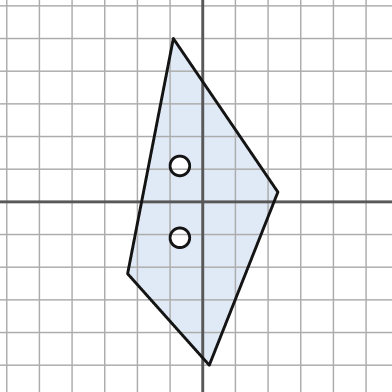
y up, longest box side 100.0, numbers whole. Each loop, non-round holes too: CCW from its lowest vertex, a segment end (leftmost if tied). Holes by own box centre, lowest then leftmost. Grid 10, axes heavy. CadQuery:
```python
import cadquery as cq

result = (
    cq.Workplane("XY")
    .moveTo(2.0, -50.0)
    .lineTo(23.0, 3.0)
    .lineTo(-9.0, 50.0)
    .lineTo(-23.0, -22.0)
    .close()
    .moveTo(-7.0, -11.0)
    .circle(3.0)
    .moveTo(-7.0, 11.0)
    .circle(3.0)
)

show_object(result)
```